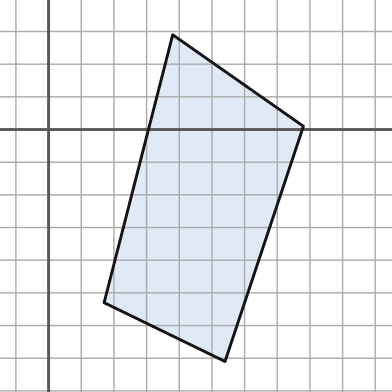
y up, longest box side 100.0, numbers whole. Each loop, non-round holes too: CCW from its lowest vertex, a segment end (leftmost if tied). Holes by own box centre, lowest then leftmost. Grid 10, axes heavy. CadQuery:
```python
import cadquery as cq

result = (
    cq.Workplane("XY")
    .moveTo(54.0, -71.0)
    .lineTo(78.0, 1.0)
    .lineTo(38.0, 29.0)
    .lineTo(17.0, -53.0)
    .close()
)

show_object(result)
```